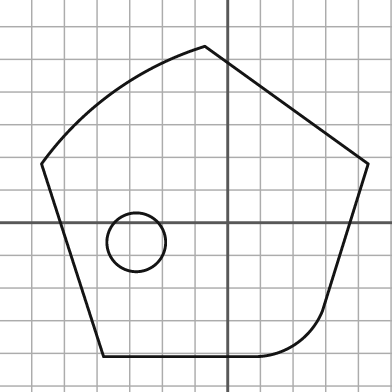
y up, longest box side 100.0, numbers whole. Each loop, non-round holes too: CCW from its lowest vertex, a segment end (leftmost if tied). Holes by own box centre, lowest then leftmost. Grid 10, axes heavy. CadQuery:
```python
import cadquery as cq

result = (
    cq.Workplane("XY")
    .moveTo(-38.0, -41.0)
    .lineTo(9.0, -41.0)
    .threePointArc((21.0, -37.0), (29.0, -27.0))
    .lineTo(43.0, 18.0)
    .lineTo(-7.0, 54.0)
    .threePointArc((-35.0, 40.0), (-57.0, 18.0))
    .close()
    .moveTo(-28.0, -6.0)
    .circle(9.0)
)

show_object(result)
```